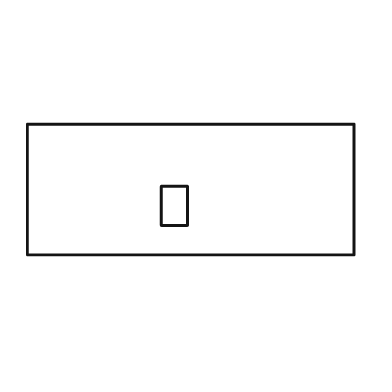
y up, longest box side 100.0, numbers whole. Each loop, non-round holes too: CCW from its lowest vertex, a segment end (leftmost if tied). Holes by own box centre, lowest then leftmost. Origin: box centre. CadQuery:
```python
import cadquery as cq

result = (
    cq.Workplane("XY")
    .moveTo(-50.0, -20.0)
    .lineTo(50.0, -20.0)
    .lineTo(50.0, 20.0)
    .lineTo(-50.0, 20.0)
    .close()
    .moveTo(-9.0, -11.0)
    .lineTo(-1.0, -11.0)
    .lineTo(-1.0, 1.0)
    .lineTo(-9.0, 1.0)
    .close()
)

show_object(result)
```